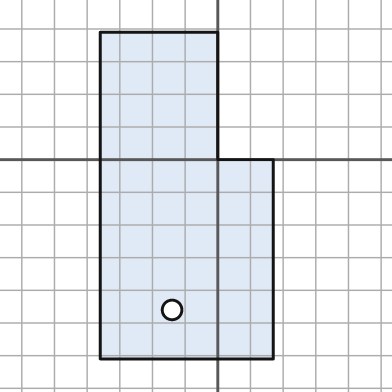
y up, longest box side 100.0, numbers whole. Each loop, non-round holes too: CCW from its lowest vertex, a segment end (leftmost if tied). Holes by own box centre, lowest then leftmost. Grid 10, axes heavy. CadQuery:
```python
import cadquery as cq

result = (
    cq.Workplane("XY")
    .moveTo(-36.0, -61.0)
    .lineTo(17.0, -61.0)
    .lineTo(17.0, 0.0)
    .lineTo(0.0, 0.0)
    .lineTo(0.0, 39.0)
    .lineTo(-36.0, 39.0)
    .close()
    .moveTo(-14.0, -46.0)
    .circle(3.0)
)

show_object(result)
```